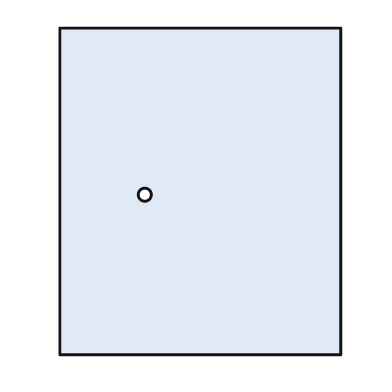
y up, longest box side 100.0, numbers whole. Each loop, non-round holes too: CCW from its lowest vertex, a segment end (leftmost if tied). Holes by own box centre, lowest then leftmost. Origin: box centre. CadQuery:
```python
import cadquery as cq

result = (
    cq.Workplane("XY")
    .moveTo(-43.0, -50.0)
    .lineTo(43.0, -50.0)
    .lineTo(43.0, 50.0)
    .lineTo(-43.0, 50.0)
    .close()
    .moveTo(-17.0, -1.0)
    .circle(2.0)
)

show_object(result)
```